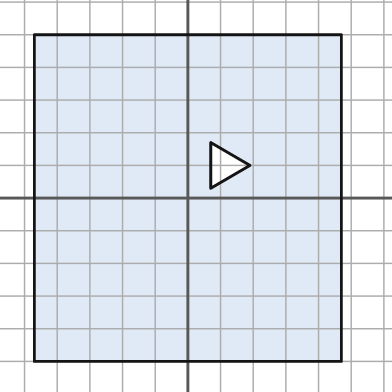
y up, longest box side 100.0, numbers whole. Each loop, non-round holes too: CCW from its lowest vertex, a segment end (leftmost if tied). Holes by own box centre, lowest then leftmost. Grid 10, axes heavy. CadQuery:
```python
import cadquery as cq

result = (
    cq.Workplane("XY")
    .moveTo(-47.0, -50.0)
    .lineTo(47.0, -50.0)
    .lineTo(47.0, 50.0)
    .lineTo(-47.0, 50.0)
    .close()
    .moveTo(7.0, 3.0)
    .lineTo(19.0, 10.0)
    .lineTo(7.0, 17.0)
    .close()
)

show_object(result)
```